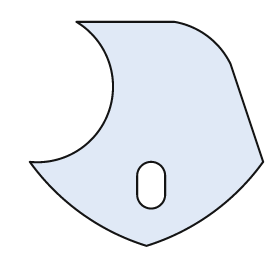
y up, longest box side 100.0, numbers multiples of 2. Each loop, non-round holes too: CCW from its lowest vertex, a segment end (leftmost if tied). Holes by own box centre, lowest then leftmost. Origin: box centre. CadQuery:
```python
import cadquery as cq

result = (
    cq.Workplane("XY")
    .moveTo(0.0, -48.0)
    .threePointArc((28.0, -34.0), (50.0, -12.0))
    .lineTo(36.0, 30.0)
    .threePointArc((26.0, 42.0), (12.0, 48.0))
    .lineTo(-30.0, 48.0)
    .threePointArc((-16.0, 10.0), (-50.0, -12.0))
    .threePointArc((-28.0, -34.0), (0.0, -48.0))
    .close()
    .moveTo(-4.0, -26.0)
    .threePointArc((2.0, -32.0), (8.0, -26.0))
    .lineTo(8.0, -18.0)
    .threePointArc((2.0, -12.0), (-4.0, -18.0))
    .close()
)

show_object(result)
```